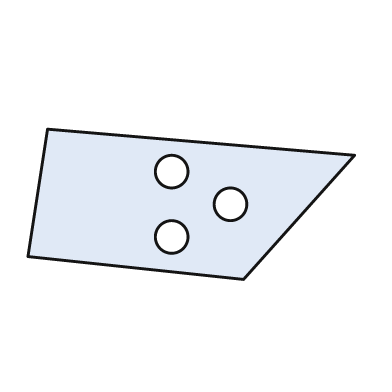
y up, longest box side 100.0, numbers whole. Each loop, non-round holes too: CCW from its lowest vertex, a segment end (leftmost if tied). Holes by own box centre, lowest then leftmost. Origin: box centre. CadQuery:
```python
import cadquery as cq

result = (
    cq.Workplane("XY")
    .moveTo(16.0, -23.0)
    .lineTo(50.0, 15.0)
    .lineTo(-44.0, 23.0)
    .lineTo(-50.0, -16.0)
    .close()
    .moveTo(-6.0, -10.0)
    .circle(5.0)
    .moveTo(12.0, 0.0)
    .circle(5.0)
    .moveTo(-6.0, 10.0)
    .circle(5.0)
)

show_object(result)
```